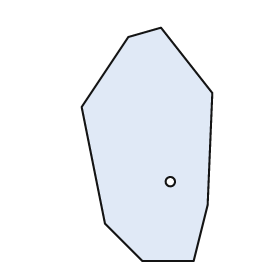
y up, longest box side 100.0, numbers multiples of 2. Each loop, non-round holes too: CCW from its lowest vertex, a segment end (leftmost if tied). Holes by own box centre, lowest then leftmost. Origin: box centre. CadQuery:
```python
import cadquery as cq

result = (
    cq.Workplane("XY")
    .moveTo(-2.0, -50.0)
    .lineTo(20.0, -50.0)
    .lineTo(26.0, -26.0)
    .lineTo(28.0, 22.0)
    .lineTo(6.0, 50.0)
    .lineTo(-8.0, 46.0)
    .lineTo(-28.0, 16.0)
    .lineTo(-18.0, -34.0)
    .close()
    .moveTo(10.0, -16.0)
    .circle(2.0)
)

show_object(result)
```